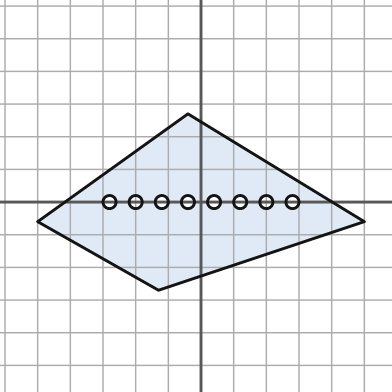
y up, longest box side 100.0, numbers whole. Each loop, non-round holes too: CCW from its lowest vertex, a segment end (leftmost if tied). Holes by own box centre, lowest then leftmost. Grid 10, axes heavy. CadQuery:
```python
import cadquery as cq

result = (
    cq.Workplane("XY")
    .moveTo(-13.0, -27.0)
    .lineTo(50.0, -6.0)
    .lineTo(-4.0, 27.0)
    .lineTo(-50.0, -6.0)
    .close()
    .moveTo(-28.0, 0.0)
    .circle(2.0)
    .moveTo(-20.0, 0.0)
    .circle(2.0)
    .moveTo(-12.0, 0.0)
    .circle(2.0)
    .moveTo(-4.0, 0.0)
    .circle(2.0)
    .moveTo(4.0, 0.0)
    .circle(2.0)
    .moveTo(12.0, 0.0)
    .circle(2.0)
    .moveTo(20.0, 0.0)
    .circle(2.0)
    .moveTo(28.0, 0.0)
    .circle(2.0)
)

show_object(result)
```